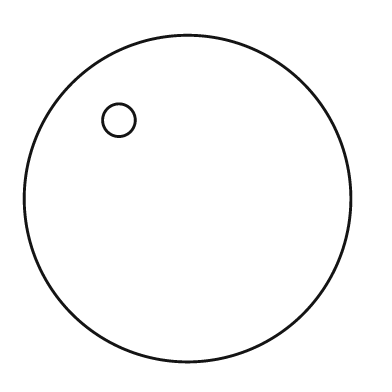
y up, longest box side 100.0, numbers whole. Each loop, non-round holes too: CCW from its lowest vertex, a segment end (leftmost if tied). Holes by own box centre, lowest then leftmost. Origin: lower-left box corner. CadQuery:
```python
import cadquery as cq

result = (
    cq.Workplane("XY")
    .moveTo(50.0, 50.0)
    .circle(50.0)
    .moveTo(29.0, 74.0)
    .circle(5.0)
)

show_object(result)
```